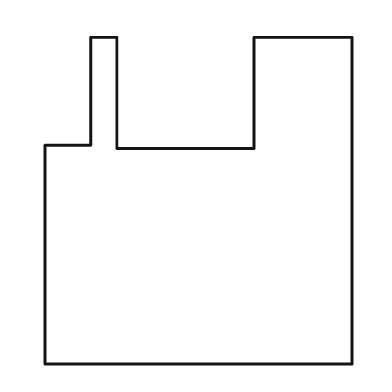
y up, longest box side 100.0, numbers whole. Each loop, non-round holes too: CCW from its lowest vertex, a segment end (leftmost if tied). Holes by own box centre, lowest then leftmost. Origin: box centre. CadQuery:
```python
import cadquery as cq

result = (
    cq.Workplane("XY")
    .moveTo(-47.0, -50.0)
    .lineTo(47.0, -50.0)
    .lineTo(47.0, 50.0)
    .lineTo(17.0, 50.0)
    .lineTo(17.0, 16.0)
    .lineTo(-25.0, 16.0)
    .lineTo(-25.0, 50.0)
    .lineTo(-33.0, 50.0)
    .lineTo(-33.0, 17.0)
    .lineTo(-47.0, 17.0)
    .close()
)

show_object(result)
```